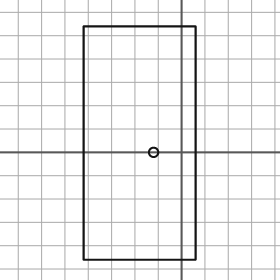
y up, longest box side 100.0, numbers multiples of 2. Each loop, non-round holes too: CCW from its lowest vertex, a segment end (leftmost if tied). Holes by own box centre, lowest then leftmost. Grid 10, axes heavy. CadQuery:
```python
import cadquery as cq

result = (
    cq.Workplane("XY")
    .moveTo(-42.0, -46.0)
    .lineTo(6.0, -46.0)
    .lineTo(6.0, 54.0)
    .lineTo(-42.0, 54.0)
    .close()
    .moveTo(-12.0, 0.0)
    .circle(2.0)
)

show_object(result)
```